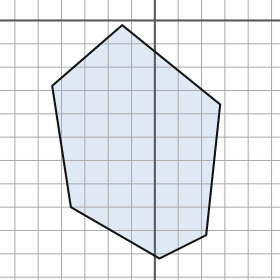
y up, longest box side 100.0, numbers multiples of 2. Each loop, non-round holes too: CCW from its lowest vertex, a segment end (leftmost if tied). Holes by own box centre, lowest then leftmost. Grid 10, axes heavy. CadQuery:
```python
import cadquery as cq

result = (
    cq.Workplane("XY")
    .moveTo(2.0, -102.0)
    .lineTo(22.0, -92.0)
    .lineTo(28.0, -36.0)
    .lineTo(-14.0, -2.0)
    .lineTo(-44.0, -28.0)
    .lineTo(-36.0, -80.0)
    .close()
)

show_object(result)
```